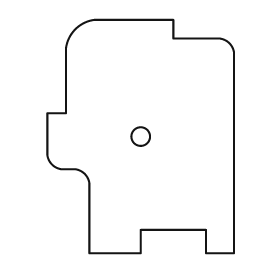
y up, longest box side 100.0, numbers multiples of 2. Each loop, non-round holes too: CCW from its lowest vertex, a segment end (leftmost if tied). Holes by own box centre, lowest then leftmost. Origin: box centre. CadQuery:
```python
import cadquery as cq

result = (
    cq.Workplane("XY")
    .moveTo(-22.0, -50.0)
    .lineTo(0.0, -50.0)
    .lineTo(0.0, -40.0)
    .lineTo(28.0, -40.0)
    .lineTo(28.0, -50.0)
    .lineTo(40.0, -50.0)
    .lineTo(40.0, 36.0)
    .threePointArc((38.0, 40.0), (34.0, 42.0))
    .lineTo(14.0, 42.0)
    .lineTo(14.0, 50.0)
    .lineTo(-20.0, 50.0)
    .threePointArc((-28.0, 46.0), (-32.0, 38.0))
    .lineTo(-32.0, 10.0)
    .lineTo(-40.0, 10.0)
    .lineTo(-40.0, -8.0)
    .threePointArc((-38.0, -12.0), (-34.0, -14.0))
    .lineTo(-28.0, -14.0)
    .threePointArc((-24.0, -16.0), (-22.0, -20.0))
    .close()
    .moveTo(0.0, 0.0)
    .circle(4.0)
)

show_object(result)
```